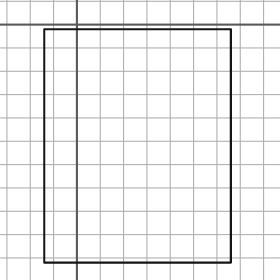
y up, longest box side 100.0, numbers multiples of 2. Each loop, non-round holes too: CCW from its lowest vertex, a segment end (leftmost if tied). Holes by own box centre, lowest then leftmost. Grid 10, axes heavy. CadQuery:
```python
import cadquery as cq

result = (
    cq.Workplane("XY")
    .moveTo(-14.0, -102.0)
    .lineTo(66.0, -102.0)
    .lineTo(66.0, -2.0)
    .lineTo(-14.0, -2.0)
    .close()
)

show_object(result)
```